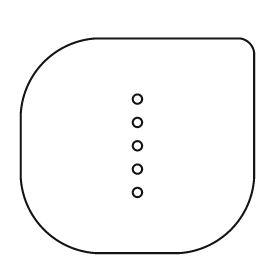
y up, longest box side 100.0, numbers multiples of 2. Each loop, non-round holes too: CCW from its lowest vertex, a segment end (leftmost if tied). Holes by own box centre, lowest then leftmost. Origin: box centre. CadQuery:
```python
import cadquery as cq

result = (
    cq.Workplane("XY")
    .moveTo(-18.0, -46.0)
    .lineTo(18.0, -46.0)
    .threePointArc((40.0, -36.0), (50.0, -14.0))
    .lineTo(50.0, 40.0)
    .threePointArc((48.0, 44.0), (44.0, 46.0))
    .lineTo(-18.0, 46.0)
    .threePointArc((-40.0, 36.0), (-50.0, 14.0))
    .lineTo(-50.0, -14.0)
    .threePointArc((-40.0, -36.0), (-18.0, -46.0))
    .close()
    .moveTo(0.0, -20.0)
    .circle(2.0)
    .moveTo(0.0, -10.0)
    .circle(2.0)
    .moveTo(0.0, 0.0)
    .circle(2.0)
    .moveTo(0.0, 10.0)
    .circle(2.0)
    .moveTo(0.0, 20.0)
    .circle(2.0)
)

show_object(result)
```